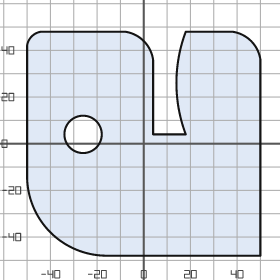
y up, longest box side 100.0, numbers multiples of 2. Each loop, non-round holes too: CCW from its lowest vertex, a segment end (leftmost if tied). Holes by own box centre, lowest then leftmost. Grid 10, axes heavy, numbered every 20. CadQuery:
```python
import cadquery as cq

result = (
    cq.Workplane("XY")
    .moveTo(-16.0, -48.0)
    .lineTo(50.0, -48.0)
    .lineTo(50.0, 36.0)
    .threePointArc((46.0, 44.0), (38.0, 48.0))
    .lineTo(18.0, 48.0)
    .threePointArc((14.0, 26.0), (18.0, 4.0))
    .lineTo(4.0, 4.0)
    .lineTo(4.0, 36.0)
    .threePointArc((0.0, 44.0), (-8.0, 48.0))
    .lineTo(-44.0, 48.0)
    .threePointArc((-48.0, 46.0), (-50.0, 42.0))
    .lineTo(-50.0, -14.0)
    .threePointArc((-40.0, -38.0), (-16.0, -48.0))
    .close()
    .moveTo(-26.0, 4.0)
    .circle(8.0)
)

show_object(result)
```